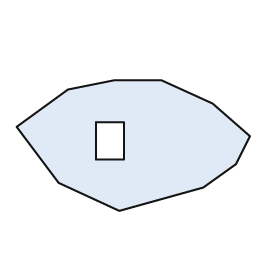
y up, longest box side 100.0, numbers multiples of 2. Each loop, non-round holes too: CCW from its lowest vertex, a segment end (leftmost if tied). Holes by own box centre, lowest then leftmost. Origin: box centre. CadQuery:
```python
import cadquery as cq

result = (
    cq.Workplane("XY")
    .moveTo(-6.0, -28.0)
    .lineTo(30.0, -18.0)
    .lineTo(44.0, -8.0)
    .lineTo(50.0, 4.0)
    .lineTo(34.0, 18.0)
    .lineTo(12.0, 28.0)
    .lineTo(-8.0, 28.0)
    .lineTo(-28.0, 24.0)
    .lineTo(-50.0, 8.0)
    .lineTo(-32.0, -16.0)
    .close()
    .moveTo(-16.0, -6.0)
    .lineTo(-4.0, -6.0)
    .lineTo(-4.0, 10.0)
    .lineTo(-16.0, 10.0)
    .close()
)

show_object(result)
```